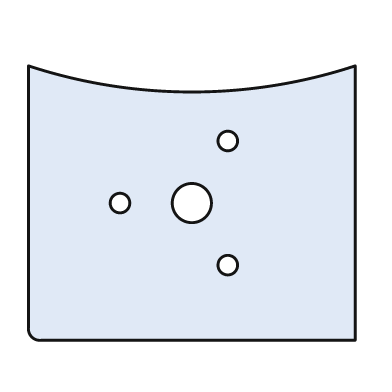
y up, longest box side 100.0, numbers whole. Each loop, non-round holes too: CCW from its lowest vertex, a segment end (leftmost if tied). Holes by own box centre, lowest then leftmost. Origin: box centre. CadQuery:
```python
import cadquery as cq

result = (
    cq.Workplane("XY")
    .moveTo(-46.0, -42.0)
    .lineTo(50.0, -42.0)
    .lineTo(50.0, 42.0)
    .threePointArc((0.0, 34.0), (-50.0, 42.0))
    .lineTo(-50.0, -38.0)
    .threePointArc((-49.0, -41.0), (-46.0, -42.0))
    .close()
    .moveTo(11.0, -19.0)
    .circle(3.0)
    .moveTo(-22.0, 0.0)
    .circle(3.0)
    .moveTo(0.0, 0.0)
    .circle(6.0)
    .moveTo(11.0, 19.0)
    .circle(3.0)
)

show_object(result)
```